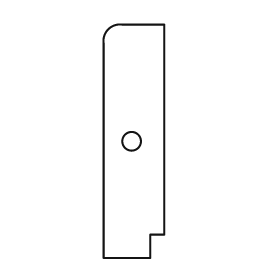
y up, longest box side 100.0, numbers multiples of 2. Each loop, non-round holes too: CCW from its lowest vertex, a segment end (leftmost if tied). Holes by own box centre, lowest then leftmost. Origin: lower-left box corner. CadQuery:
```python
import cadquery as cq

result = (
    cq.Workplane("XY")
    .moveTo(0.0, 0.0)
    .lineTo(20.0, 0.0)
    .lineTo(20.0, 10.0)
    .lineTo(26.0, 10.0)
    .lineTo(26.0, 100.0)
    .lineTo(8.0, 100.0)
    .threePointArc((2.0, 98.0), (0.0, 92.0))
    .close()
    .moveTo(12.0, 50.0)
    .circle(4.0)
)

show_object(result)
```